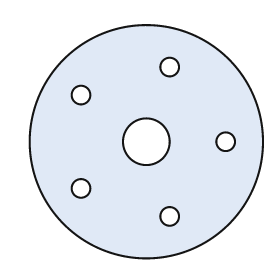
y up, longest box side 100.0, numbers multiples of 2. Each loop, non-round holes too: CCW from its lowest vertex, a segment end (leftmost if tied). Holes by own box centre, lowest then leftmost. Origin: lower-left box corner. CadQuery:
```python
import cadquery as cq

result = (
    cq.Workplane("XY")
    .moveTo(50.0, 50.0)
    .circle(50.0)
    .moveTo(60.0, 18.0)
    .circle(4.0)
    .moveTo(22.0, 30.0)
    .circle(4.0)
    .moveTo(50.0, 50.0)
    .circle(10.0)
    .moveTo(84.0, 50.0)
    .circle(4.0)
    .moveTo(22.0, 70.0)
    .circle(4.0)
    .moveTo(60.0, 82.0)
    .circle(4.0)
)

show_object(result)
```